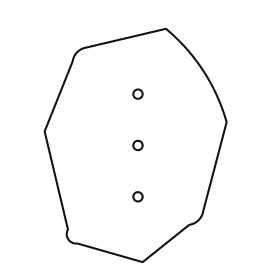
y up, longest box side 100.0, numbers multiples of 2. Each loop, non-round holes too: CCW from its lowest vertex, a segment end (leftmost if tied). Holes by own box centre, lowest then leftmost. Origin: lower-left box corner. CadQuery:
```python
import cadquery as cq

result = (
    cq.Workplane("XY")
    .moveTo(42.0, 0.0)
    .lineTo(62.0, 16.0)
    .threePointArc((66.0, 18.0), (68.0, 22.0))
    .lineTo(78.0, 60.0)
    .threePointArc((68.0, 82.0), (52.0, 100.0))
    .lineTo(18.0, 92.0)
    .threePointArc((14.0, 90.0), (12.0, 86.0))
    .lineTo(0.0, 56.0)
    .lineTo(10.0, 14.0)
    .threePointArc((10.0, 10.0), (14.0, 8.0))
    .close()
    .moveTo(40.0, 28.0)
    .circle(2.0)
    .moveTo(40.0, 50.0)
    .circle(2.0)
    .moveTo(40.0, 72.0)
    .circle(2.0)
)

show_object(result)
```